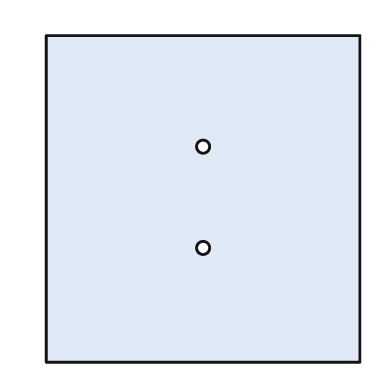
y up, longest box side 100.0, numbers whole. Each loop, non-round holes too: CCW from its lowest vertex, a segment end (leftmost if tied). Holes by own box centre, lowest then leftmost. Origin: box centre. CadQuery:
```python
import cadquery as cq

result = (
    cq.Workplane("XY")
    .moveTo(-48.0, -50.0)
    .lineTo(48.0, -50.0)
    .lineTo(48.0, 50.0)
    .lineTo(-48.0, 50.0)
    .close()
    .moveTo(0.0, -15.0)
    .circle(2.0)
    .moveTo(0.0, 16.0)
    .circle(2.0)
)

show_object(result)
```